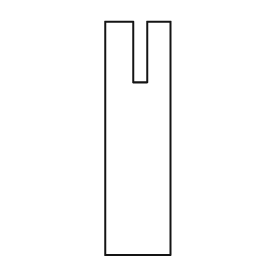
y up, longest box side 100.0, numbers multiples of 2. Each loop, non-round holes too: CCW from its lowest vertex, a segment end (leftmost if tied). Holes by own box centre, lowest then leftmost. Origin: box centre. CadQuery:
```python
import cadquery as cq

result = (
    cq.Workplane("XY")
    .moveTo(-14.0, -50.0)
    .lineTo(14.0, -50.0)
    .lineTo(14.0, 50.0)
    .lineTo(4.0, 50.0)
    .lineTo(4.0, 24.0)
    .lineTo(-2.0, 24.0)
    .lineTo(-2.0, 50.0)
    .lineTo(-14.0, 50.0)
    .close()
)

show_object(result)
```